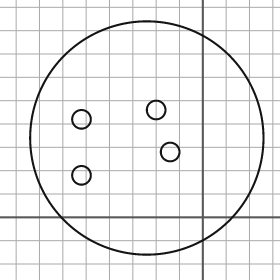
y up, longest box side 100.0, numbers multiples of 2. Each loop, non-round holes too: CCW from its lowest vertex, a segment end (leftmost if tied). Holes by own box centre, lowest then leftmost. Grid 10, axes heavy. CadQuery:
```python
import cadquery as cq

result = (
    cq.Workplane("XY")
    .moveTo(-24.0, 34.0)
    .circle(50.0)
    .moveTo(-52.0, 18.0)
    .circle(4.0)
    .moveTo(-14.0, 28.0)
    .circle(4.0)
    .moveTo(-52.0, 42.0)
    .circle(4.0)
    .moveTo(-20.0, 46.0)
    .circle(4.0)
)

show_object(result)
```